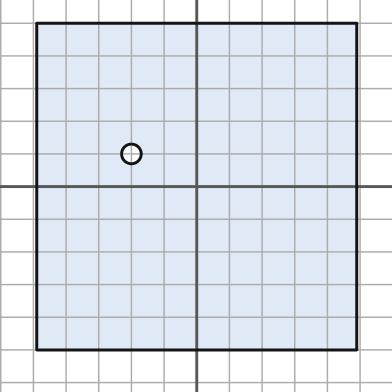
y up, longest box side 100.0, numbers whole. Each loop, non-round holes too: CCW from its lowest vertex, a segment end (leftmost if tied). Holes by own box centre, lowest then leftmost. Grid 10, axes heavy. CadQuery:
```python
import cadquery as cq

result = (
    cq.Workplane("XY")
    .moveTo(-49.0, -50.0)
    .lineTo(49.0, -50.0)
    .lineTo(49.0, 50.0)
    .lineTo(-49.0, 50.0)
    .close()
    .moveTo(-20.0, 10.0)
    .circle(3.0)
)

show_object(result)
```